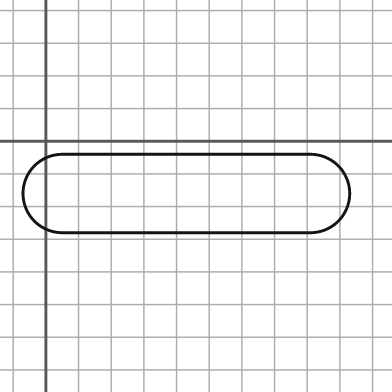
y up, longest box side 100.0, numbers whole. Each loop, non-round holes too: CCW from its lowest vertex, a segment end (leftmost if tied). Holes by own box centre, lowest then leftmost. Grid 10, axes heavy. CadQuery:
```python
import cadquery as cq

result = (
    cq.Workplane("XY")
    .moveTo(5.0, -28.0)
    .lineTo(81.0, -28.0)
    .threePointArc((93.0, -16.0), (81.0, -4.0))
    .lineTo(5.0, -4.0)
    .threePointArc((-7.0, -16.0), (5.0, -28.0))
    .close()
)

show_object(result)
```